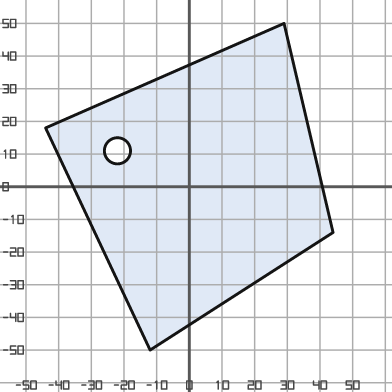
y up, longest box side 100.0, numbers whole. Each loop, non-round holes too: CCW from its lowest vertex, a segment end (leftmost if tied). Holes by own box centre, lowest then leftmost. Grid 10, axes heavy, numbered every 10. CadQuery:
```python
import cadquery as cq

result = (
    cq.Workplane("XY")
    .moveTo(-12.0, -50.0)
    .lineTo(44.0, -14.0)
    .lineTo(29.0, 50.0)
    .lineTo(-44.0, 18.0)
    .close()
    .moveTo(-22.0, 11.0)
    .circle(4.0)
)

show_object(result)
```